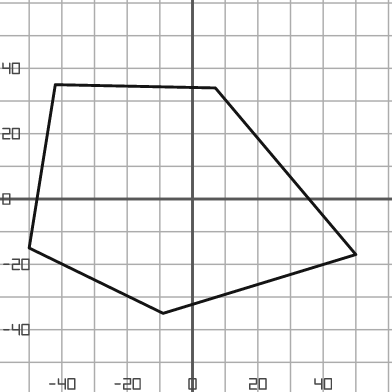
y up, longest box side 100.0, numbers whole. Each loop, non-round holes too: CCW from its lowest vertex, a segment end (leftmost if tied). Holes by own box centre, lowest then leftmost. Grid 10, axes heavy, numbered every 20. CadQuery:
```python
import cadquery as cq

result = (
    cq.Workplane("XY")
    .moveTo(-9.0, -35.0)
    .lineTo(50.0, -17.0)
    .lineTo(7.0, 34.0)
    .lineTo(-42.0, 35.0)
    .lineTo(-50.0, -15.0)
    .close()
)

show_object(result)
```